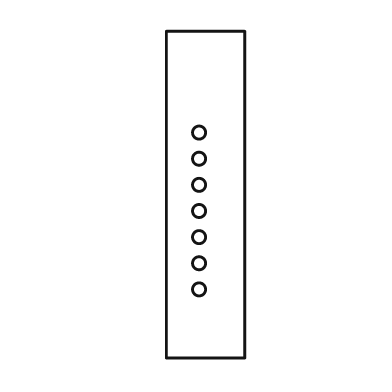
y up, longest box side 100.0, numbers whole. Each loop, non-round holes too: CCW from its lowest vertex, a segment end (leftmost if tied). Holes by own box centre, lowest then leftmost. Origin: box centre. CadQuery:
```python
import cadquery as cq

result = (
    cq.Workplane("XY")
    .moveTo(-12.0, -50.0)
    .lineTo(12.0, -50.0)
    .lineTo(12.0, 50.0)
    .lineTo(-12.0, 50.0)
    .close()
    .moveTo(-2.0, -29.0)
    .circle(2.0)
    .moveTo(-2.0, -21.0)
    .circle(2.0)
    .moveTo(-2.0, -13.0)
    .circle(2.0)
    .moveTo(-2.0, -5.0)
    .circle(2.0)
    .moveTo(-2.0, 3.0)
    .circle(2.0)
    .moveTo(-2.0, 11.0)
    .circle(2.0)
    .moveTo(-2.0, 19.0)
    .circle(2.0)
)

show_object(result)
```